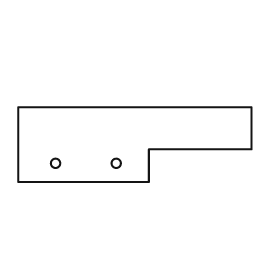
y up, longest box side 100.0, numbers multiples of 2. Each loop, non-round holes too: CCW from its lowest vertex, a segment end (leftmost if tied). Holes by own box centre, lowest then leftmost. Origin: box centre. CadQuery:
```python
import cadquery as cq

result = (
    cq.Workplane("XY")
    .moveTo(-50.0, -16.0)
    .lineTo(6.0, -16.0)
    .lineTo(6.0, -2.0)
    .lineTo(50.0, -2.0)
    .lineTo(50.0, 16.0)
    .lineTo(-50.0, 16.0)
    .close()
    .moveTo(-34.0, -8.0)
    .circle(2.0)
    .moveTo(-8.0, -8.0)
    .circle(2.0)
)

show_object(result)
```